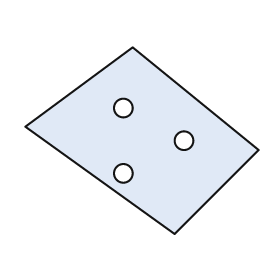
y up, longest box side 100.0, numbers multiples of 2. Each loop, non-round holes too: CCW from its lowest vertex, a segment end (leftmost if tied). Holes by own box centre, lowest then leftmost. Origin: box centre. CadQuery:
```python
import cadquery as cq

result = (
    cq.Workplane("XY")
    .moveTo(14.0, -40.0)
    .lineTo(50.0, -4.0)
    .lineTo(-4.0, 40.0)
    .lineTo(-50.0, 6.0)
    .close()
    .moveTo(-8.0, -14.0)
    .circle(4.0)
    .moveTo(18.0, 0.0)
    .circle(4.0)
    .moveTo(-8.0, 14.0)
    .circle(4.0)
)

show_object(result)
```